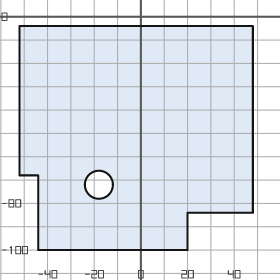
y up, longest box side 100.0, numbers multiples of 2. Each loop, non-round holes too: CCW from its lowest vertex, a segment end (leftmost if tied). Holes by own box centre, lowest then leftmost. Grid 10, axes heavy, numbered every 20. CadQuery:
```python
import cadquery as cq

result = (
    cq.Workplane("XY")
    .moveTo(-44.0, -100.0)
    .lineTo(20.0, -100.0)
    .lineTo(20.0, -84.0)
    .lineTo(48.0, -84.0)
    .lineTo(48.0, -4.0)
    .lineTo(-52.0, -4.0)
    .lineTo(-52.0, -68.0)
    .lineTo(-44.0, -68.0)
    .close()
    .moveTo(-18.0, -72.0)
    .circle(6.0)
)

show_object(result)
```